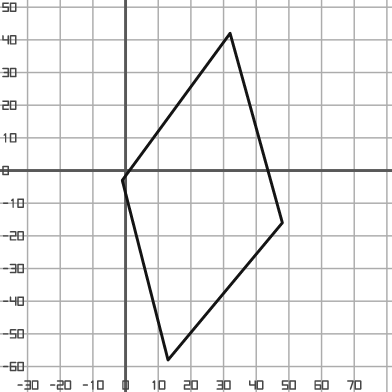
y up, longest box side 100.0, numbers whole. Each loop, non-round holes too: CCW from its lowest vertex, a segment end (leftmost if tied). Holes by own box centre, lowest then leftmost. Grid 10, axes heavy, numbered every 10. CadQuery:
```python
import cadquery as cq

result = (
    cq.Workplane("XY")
    .moveTo(13.0, -58.0)
    .lineTo(48.0, -16.0)
    .lineTo(32.0, 42.0)
    .lineTo(-1.0, -3.0)
    .close()
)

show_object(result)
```